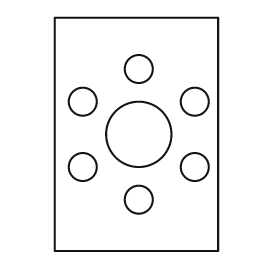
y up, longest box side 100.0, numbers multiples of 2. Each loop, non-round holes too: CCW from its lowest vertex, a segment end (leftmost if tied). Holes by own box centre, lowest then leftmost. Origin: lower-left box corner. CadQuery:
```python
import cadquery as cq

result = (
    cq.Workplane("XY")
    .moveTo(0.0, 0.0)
    .lineTo(70.0, 0.0)
    .lineTo(70.0, 100.0)
    .lineTo(0.0, 100.0)
    .close()
    .moveTo(36.0, 22.0)
    .circle(6.0)
    .moveTo(12.0, 36.0)
    .circle(6.0)
    .moveTo(60.0, 36.0)
    .circle(6.0)
    .moveTo(36.0, 50.0)
    .circle(14.0)
    .moveTo(12.0, 64.0)
    .circle(6.0)
    .moveTo(60.0, 64.0)
    .circle(6.0)
    .moveTo(36.0, 78.0)
    .circle(6.0)
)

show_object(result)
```